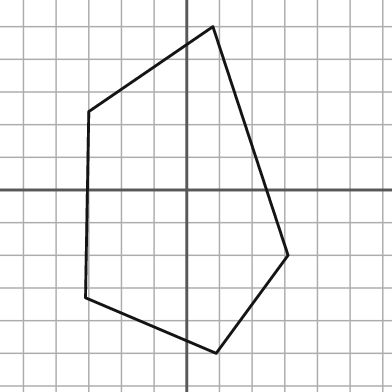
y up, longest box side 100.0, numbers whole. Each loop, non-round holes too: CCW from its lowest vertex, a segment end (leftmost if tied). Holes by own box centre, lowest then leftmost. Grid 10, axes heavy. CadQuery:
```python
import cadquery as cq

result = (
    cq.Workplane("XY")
    .moveTo(9.0, -50.0)
    .lineTo(31.0, -20.0)
    .lineTo(8.0, 50.0)
    .lineTo(-30.0, 24.0)
    .lineTo(-31.0, -33.0)
    .close()
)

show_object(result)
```